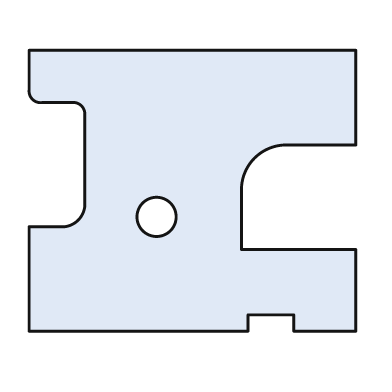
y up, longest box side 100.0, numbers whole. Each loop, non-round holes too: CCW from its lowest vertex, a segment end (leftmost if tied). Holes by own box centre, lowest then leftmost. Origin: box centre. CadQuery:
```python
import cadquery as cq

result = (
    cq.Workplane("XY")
    .moveTo(-50.0, -43.0)
    .lineTo(17.0, -43.0)
    .lineTo(17.0, -38.0)
    .lineTo(31.0, -38.0)
    .lineTo(31.0, -43.0)
    .lineTo(50.0, -43.0)
    .lineTo(50.0, -18.0)
    .lineTo(15.0, -18.0)
    .lineTo(15.0, 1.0)
    .threePointArc((19.0, 10.0), (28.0, 14.0))
    .lineTo(50.0, 14.0)
    .lineTo(50.0, 43.0)
    .lineTo(-50.0, 43.0)
    .lineTo(-50.0, 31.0)
    .threePointArc((-49.0, 28.0), (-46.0, 27.0))
    .lineTo(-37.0, 27.0)
    .threePointArc((-34.0, 26.0), (-33.0, 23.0))
    .lineTo(-33.0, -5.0)
    .threePointArc((-35.0, -9.0), (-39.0, -11.0))
    .lineTo(-50.0, -11.0)
    .close()
    .moveTo(-11.0, -8.0)
    .circle(6.0)
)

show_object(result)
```